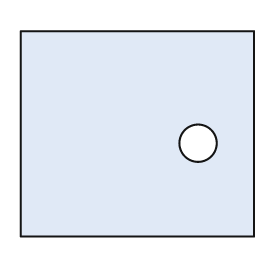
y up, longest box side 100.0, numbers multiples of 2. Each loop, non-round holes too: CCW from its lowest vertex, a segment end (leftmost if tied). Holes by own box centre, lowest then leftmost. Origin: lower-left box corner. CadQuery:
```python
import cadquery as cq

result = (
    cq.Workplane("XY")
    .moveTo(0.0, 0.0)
    .lineTo(100.0, 0.0)
    .lineTo(100.0, 88.0)
    .lineTo(0.0, 88.0)
    .close()
    .moveTo(76.0, 40.0)
    .circle(8.0)
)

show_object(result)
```